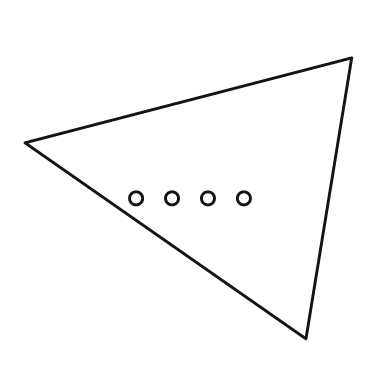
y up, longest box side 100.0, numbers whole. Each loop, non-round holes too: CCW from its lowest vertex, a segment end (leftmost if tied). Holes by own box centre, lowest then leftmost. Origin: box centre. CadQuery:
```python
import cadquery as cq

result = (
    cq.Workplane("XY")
    .moveTo(36.0, -43.0)
    .lineTo(50.0, 43.0)
    .lineTo(-50.0, 17.0)
    .close()
    .moveTo(-16.0, 0.0)
    .circle(2.0)
    .moveTo(-5.0, 0.0)
    .circle(2.0)
    .moveTo(6.0, 0.0)
    .circle(2.0)
    .moveTo(17.0, 0.0)
    .circle(2.0)
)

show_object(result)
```